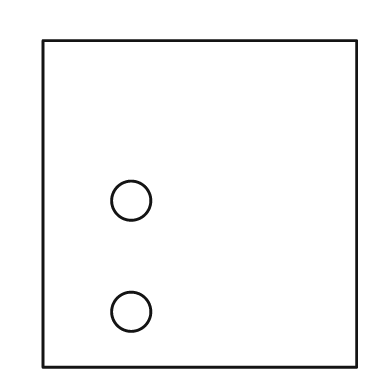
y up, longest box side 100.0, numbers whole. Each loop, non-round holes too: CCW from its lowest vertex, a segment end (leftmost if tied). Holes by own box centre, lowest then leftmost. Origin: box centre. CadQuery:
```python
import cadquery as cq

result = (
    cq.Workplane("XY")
    .moveTo(-48.0, -50.0)
    .lineTo(48.0, -50.0)
    .lineTo(48.0, 50.0)
    .lineTo(-48.0, 50.0)
    .close()
    .moveTo(-21.0, -33.0)
    .circle(6.0)
    .moveTo(-21.0, 1.0)
    .circle(6.0)
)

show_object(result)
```